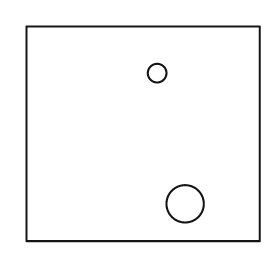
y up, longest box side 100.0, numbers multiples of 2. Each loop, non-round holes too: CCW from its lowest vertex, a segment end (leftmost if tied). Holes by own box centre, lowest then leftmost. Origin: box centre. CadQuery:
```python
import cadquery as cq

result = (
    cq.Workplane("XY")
    .moveTo(-50.0, -46.0)
    .lineTo(50.0, -46.0)
    .lineTo(50.0, 46.0)
    .lineTo(-50.0, 46.0)
    .close()
    .moveTo(18.0, -30.0)
    .circle(8.0)
    .moveTo(6.0, 26.0)
    .circle(4.0)
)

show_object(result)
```